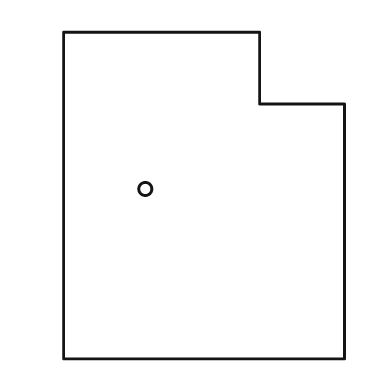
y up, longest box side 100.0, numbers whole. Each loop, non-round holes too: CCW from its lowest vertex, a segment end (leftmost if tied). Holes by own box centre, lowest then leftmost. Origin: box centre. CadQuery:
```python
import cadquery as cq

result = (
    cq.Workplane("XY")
    .moveTo(-43.0, -50.0)
    .lineTo(43.0, -50.0)
    .lineTo(43.0, 28.0)
    .lineTo(17.0, 28.0)
    .lineTo(17.0, 50.0)
    .lineTo(-43.0, 50.0)
    .close()
    .moveTo(-18.0, 2.0)
    .circle(2.0)
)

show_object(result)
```